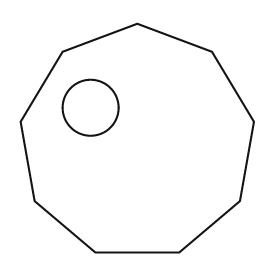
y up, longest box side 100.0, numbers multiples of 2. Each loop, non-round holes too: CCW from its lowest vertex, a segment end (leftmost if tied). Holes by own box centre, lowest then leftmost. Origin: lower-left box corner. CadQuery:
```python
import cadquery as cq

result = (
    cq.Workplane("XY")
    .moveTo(32.0, 0.0)
    .lineTo(68.0, 0.0)
    .lineTo(94.0, 22.0)
    .lineTo(100.0, 56.0)
    .lineTo(82.0, 86.0)
    .lineTo(50.0, 98.0)
    .lineTo(18.0, 86.0)
    .lineTo(0.0, 56.0)
    .lineTo(6.0, 22.0)
    .close()
    .moveTo(30.0, 62.0)
    .circle(12.0)
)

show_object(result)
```